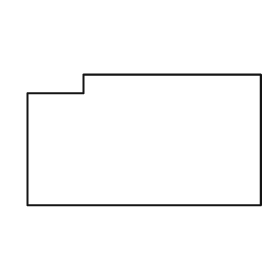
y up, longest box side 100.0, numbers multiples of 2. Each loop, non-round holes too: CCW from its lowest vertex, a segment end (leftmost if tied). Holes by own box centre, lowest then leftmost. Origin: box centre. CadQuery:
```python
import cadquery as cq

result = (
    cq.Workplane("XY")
    .moveTo(-50.0, -28.0)
    .lineTo(50.0, -28.0)
    .lineTo(50.0, 28.0)
    .lineTo(-26.0, 28.0)
    .lineTo(-26.0, 20.0)
    .lineTo(-50.0, 20.0)
    .close()
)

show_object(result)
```